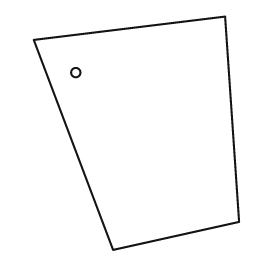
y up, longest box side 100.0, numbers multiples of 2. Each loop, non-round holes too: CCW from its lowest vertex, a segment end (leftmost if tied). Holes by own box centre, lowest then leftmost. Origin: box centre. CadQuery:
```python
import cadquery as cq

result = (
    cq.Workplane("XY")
    .moveTo(-10.0, -50.0)
    .lineTo(44.0, -38.0)
    .lineTo(38.0, 50.0)
    .lineTo(-44.0, 40.0)
    .close()
    .moveTo(-26.0, 26.0)
    .circle(2.0)
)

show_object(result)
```